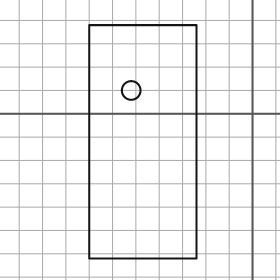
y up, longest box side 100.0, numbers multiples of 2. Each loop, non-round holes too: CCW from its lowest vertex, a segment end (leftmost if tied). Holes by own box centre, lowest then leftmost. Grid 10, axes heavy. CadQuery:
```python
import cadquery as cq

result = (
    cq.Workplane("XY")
    .moveTo(-70.0, -62.0)
    .lineTo(-24.0, -62.0)
    .lineTo(-24.0, 38.0)
    .lineTo(-70.0, 38.0)
    .close()
    .moveTo(-52.0, 10.0)
    .circle(4.0)
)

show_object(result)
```